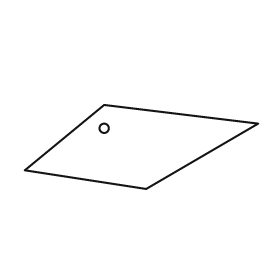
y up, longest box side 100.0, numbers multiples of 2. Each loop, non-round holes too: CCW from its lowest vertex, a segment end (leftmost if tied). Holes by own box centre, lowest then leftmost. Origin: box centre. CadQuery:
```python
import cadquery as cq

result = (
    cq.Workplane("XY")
    .moveTo(2.0, -18.0)
    .lineTo(50.0, 10.0)
    .lineTo(-16.0, 18.0)
    .lineTo(-50.0, -10.0)
    .close()
    .moveTo(-16.0, 8.0)
    .circle(2.0)
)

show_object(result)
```